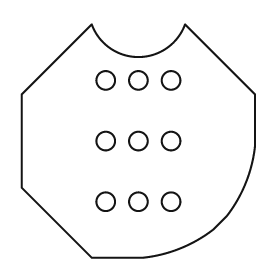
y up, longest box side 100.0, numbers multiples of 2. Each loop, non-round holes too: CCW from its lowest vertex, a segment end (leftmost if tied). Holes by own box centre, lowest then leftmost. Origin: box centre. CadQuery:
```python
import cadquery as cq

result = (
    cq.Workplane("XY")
    .moveTo(-20.0, -50.0)
    .lineTo(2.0, -50.0)
    .threePointArc((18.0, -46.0), (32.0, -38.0))
    .lineTo(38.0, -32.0)
    .threePointArc((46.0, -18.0), (50.0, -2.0))
    .lineTo(50.0, 20.0)
    .lineTo(20.0, 50.0)
    .threePointArc((0.0, 36.0), (-20.0, 50.0))
    .lineTo(-50.0, 20.0)
    .lineTo(-50.0, -20.0)
    .close()
    .moveTo(-14.0, -26.0)
    .circle(4.0)
    .moveTo(0.0, -26.0)
    .circle(4.0)
    .moveTo(14.0, -26.0)
    .circle(4.0)
    .moveTo(-14.0, 0.0)
    .circle(4.0)
    .moveTo(0.0, 0.0)
    .circle(4.0)
    .moveTo(14.0, 0.0)
    .circle(4.0)
    .moveTo(-14.0, 26.0)
    .circle(4.0)
    .moveTo(0.0, 26.0)
    .circle(4.0)
    .moveTo(14.0, 26.0)
    .circle(4.0)
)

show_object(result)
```